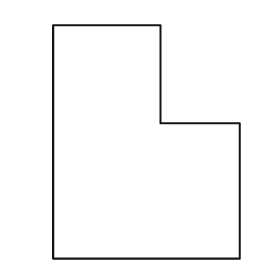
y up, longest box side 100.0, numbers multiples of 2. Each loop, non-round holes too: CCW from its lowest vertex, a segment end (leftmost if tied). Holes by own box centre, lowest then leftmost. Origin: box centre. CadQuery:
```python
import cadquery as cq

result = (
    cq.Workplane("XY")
    .moveTo(-40.0, -50.0)
    .lineTo(40.0, -50.0)
    .lineTo(40.0, 8.0)
    .lineTo(6.0, 8.0)
    .lineTo(6.0, 50.0)
    .lineTo(-40.0, 50.0)
    .close()
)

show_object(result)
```